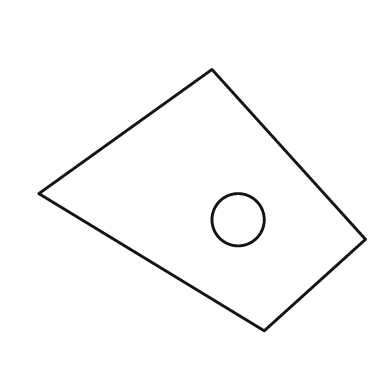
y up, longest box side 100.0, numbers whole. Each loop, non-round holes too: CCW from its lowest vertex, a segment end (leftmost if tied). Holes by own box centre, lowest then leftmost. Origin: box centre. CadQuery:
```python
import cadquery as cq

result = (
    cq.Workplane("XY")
    .moveTo(19.0, -40.0)
    .lineTo(50.0, -12.0)
    .lineTo(3.0, 40.0)
    .lineTo(-50.0, 2.0)
    .close()
    .moveTo(11.0, -6.0)
    .circle(8.0)
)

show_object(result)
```